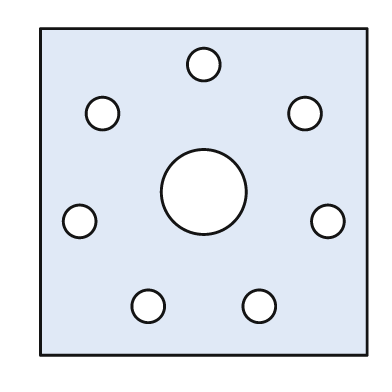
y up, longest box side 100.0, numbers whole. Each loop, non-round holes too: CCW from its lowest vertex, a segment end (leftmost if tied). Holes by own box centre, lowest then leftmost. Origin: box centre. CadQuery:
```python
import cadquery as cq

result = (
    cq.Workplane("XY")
    .moveTo(-50.0, -50.0)
    .lineTo(50.0, -50.0)
    .lineTo(50.0, 50.0)
    .lineTo(-50.0, 50.0)
    .close()
    .moveTo(-17.0, -35.0)
    .circle(5.0)
    .moveTo(17.0, -35.0)
    .circle(5.0)
    .moveTo(-38.0, -9.0)
    .circle(5.0)
    .moveTo(38.0, -9.0)
    .circle(5.0)
    .moveTo(0.0, 0.0)
    .circle(13.0)
    .moveTo(-31.0, 24.0)
    .circle(5.0)
    .moveTo(31.0, 24.0)
    .circle(5.0)
    .moveTo(0.0, 39.0)
    .circle(5.0)
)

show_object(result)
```